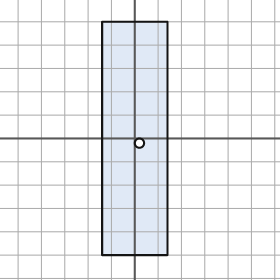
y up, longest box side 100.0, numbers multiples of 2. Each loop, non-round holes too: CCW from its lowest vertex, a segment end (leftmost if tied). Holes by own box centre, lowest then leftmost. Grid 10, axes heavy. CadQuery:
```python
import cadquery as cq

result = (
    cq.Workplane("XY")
    .moveTo(-14.0, -50.0)
    .lineTo(14.0, -50.0)
    .lineTo(14.0, 50.0)
    .lineTo(-14.0, 50.0)
    .close()
    .moveTo(2.0, -2.0)
    .circle(2.0)
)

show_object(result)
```